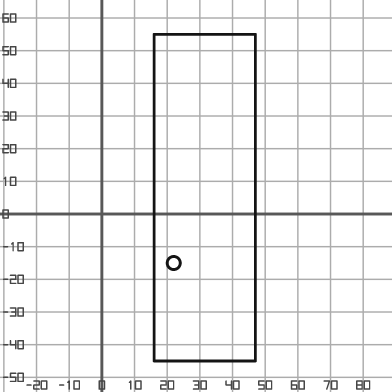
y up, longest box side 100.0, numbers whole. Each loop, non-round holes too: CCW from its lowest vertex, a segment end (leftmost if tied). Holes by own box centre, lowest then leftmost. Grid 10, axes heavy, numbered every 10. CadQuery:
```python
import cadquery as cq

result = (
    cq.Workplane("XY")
    .moveTo(16.0, -45.0)
    .lineTo(47.0, -45.0)
    .lineTo(47.0, 55.0)
    .lineTo(16.0, 55.0)
    .close()
    .moveTo(22.0, -15.0)
    .circle(2.0)
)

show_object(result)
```